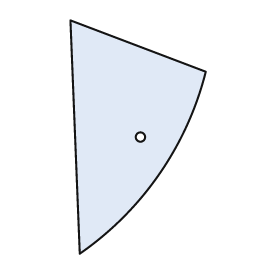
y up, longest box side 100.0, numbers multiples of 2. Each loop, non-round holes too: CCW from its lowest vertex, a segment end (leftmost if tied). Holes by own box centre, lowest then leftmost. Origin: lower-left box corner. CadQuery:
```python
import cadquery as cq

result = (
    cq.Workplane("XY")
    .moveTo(4.0, 0.0)
    .threePointArc((38.0, 34.0), (58.0, 78.0))
    .lineTo(0.0, 100.0)
    .close()
    .moveTo(30.0, 50.0)
    .circle(2.0)
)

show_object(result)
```